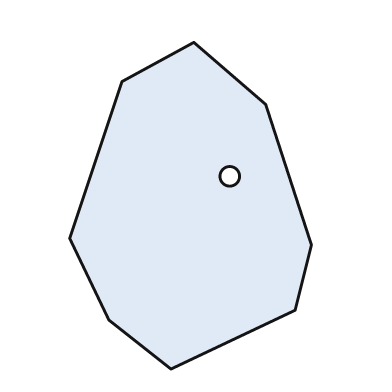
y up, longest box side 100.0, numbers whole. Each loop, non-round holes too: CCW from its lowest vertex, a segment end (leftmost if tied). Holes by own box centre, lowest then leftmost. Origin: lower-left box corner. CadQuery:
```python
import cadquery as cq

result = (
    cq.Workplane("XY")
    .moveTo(31.0, 0.0)
    .lineTo(69.0, 18.0)
    .lineTo(74.0, 38.0)
    .lineTo(60.0, 81.0)
    .lineTo(38.0, 100.0)
    .lineTo(16.0, 88.0)
    .lineTo(0.0, 40.0)
    .lineTo(12.0, 15.0)
    .close()
    .moveTo(49.0, 59.0)
    .circle(3.0)
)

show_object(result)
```